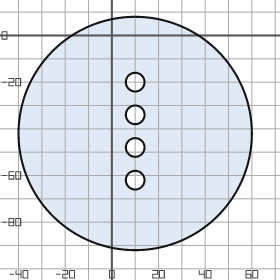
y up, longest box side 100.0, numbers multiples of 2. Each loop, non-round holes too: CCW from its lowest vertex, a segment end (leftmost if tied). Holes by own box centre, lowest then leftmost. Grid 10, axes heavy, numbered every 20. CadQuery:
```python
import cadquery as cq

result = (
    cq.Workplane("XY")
    .moveTo(10.0, -42.0)
    .circle(50.0)
    .moveTo(10.0, -62.0)
    .circle(4.0)
    .moveTo(10.0, -48.0)
    .circle(4.0)
    .moveTo(10.0, -34.0)
    .circle(4.0)
    .moveTo(10.0, -20.0)
    .circle(4.0)
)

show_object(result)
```